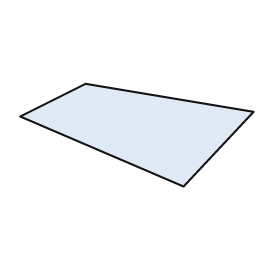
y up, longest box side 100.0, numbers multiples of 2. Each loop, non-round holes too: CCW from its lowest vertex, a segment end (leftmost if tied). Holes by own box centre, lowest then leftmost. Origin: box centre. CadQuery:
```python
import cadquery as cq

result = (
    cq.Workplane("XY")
    .moveTo(20.0, -22.0)
    .lineTo(50.0, 10.0)
    .lineTo(-22.0, 22.0)
    .lineTo(-50.0, 8.0)
    .close()
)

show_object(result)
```